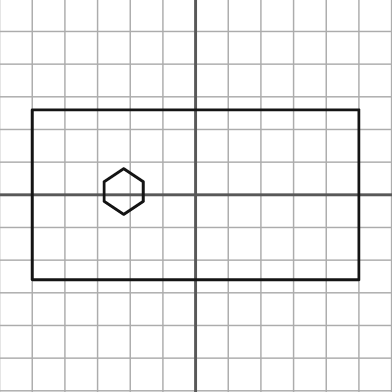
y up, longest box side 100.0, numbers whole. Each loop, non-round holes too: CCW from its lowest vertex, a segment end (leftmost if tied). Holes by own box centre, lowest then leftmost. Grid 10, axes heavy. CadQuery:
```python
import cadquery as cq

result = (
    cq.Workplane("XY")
    .moveTo(-50.0, -26.0)
    .lineTo(50.0, -26.0)
    .lineTo(50.0, 26.0)
    .lineTo(-50.0, 26.0)
    .close()
    .moveTo(-22.0, -6.0)
    .lineTo(-16.0, -2.0)
    .lineTo(-16.0, 4.0)
    .lineTo(-22.0, 8.0)
    .lineTo(-28.0, 4.0)
    .lineTo(-28.0, -2.0)
    .close()
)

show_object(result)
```